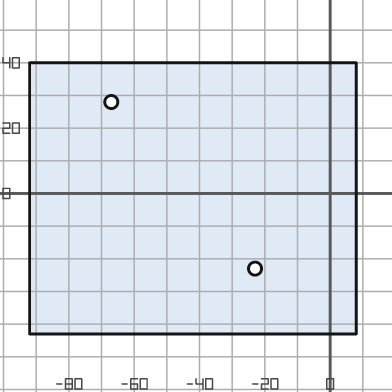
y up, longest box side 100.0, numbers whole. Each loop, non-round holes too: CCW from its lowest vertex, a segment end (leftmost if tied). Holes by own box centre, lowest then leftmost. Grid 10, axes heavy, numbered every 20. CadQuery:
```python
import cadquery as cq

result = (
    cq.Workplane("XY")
    .moveTo(-92.0, -43.0)
    .lineTo(8.0, -43.0)
    .lineTo(8.0, 40.0)
    .lineTo(-92.0, 40.0)
    .close()
    .moveTo(-23.0, -23.0)
    .circle(2.0)
    .moveTo(-67.0, 28.0)
    .circle(2.0)
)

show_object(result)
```